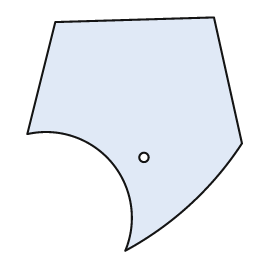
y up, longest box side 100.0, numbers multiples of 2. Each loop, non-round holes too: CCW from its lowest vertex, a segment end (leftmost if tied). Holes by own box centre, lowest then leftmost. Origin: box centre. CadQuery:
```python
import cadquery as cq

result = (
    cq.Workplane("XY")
    .moveTo(-4.0, -50.0)
    .threePointArc((24.0, -30.0), (46.0, -4.0))
    .lineTo(34.0, 50.0)
    .lineTo(-34.0, 48.0)
    .lineTo(-46.0, 0.0)
    .threePointArc((-10.0, -12.0), (-4.0, -50.0))
    .close()
    .moveTo(4.0, -10.0)
    .circle(2.0)
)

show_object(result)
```